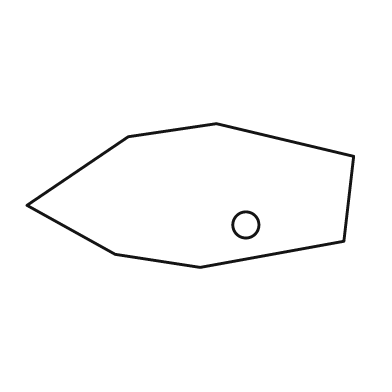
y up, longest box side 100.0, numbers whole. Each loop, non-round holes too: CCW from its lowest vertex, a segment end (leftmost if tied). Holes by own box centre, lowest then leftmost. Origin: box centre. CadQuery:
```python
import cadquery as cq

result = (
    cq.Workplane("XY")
    .moveTo(3.0, -22.0)
    .lineTo(47.0, -14.0)
    .lineTo(50.0, 12.0)
    .lineTo(8.0, 22.0)
    .lineTo(-19.0, 18.0)
    .lineTo(-50.0, -3.0)
    .lineTo(-23.0, -18.0)
    .close()
    .moveTo(17.0, -9.0)
    .circle(4.0)
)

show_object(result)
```